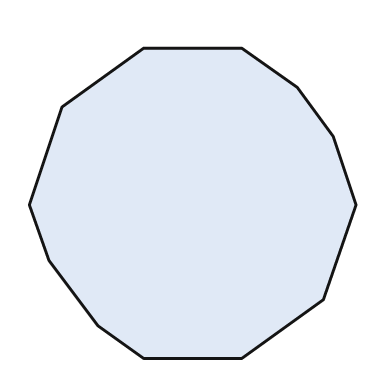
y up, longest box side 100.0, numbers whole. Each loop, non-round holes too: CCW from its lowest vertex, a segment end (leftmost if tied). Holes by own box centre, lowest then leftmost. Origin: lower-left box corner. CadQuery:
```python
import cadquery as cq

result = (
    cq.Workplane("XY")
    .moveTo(35.0, 0.0)
    .lineTo(65.0, 0.0)
    .lineTo(90.0, 18.0)
    .lineTo(100.0, 47.0)
    .lineTo(93.0, 68.0)
    .lineTo(82.0, 83.0)
    .lineTo(65.0, 95.0)
    .lineTo(35.0, 95.0)
    .lineTo(10.0, 77.0)
    .lineTo(0.0, 47.0)
    .lineTo(6.0, 30.0)
    .lineTo(21.0, 10.0)
    .close()
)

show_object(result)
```